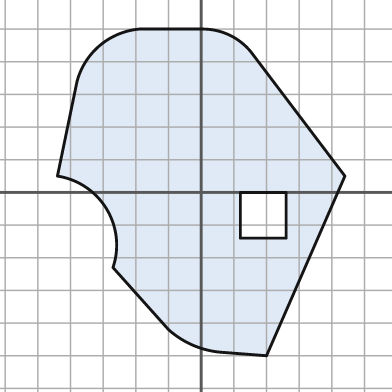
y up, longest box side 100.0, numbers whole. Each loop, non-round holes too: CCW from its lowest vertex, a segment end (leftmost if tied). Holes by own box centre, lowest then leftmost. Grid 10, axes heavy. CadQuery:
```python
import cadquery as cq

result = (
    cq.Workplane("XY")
    .moveTo(20.0, -50.0)
    .lineTo(44.0, 5.0)
    .lineTo(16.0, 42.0)
    .threePointArc((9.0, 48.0), (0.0, 50.0))
    .lineTo(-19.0, 50.0)
    .threePointArc((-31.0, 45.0), (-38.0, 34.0))
    .lineTo(-44.0, 5.0)
    .threePointArc((-29.0, -5.0), (-27.0, -23.0))
    .lineTo(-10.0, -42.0)
    .threePointArc((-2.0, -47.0), (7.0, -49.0))
    .close()
    .moveTo(12.0, -14.0)
    .lineTo(26.0, -14.0)
    .lineTo(26.0, 0.0)
    .lineTo(12.0, 0.0)
    .close()
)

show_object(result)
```